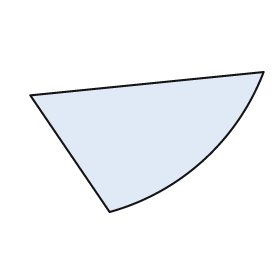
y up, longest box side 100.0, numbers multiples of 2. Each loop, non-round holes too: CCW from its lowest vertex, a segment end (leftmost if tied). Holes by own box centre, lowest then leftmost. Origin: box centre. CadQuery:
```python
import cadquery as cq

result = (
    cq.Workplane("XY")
    .moveTo(-16.0, -30.0)
    .threePointArc((24.0, -8.0), (50.0, 30.0))
    .lineTo(-50.0, 20.0)
    .close()
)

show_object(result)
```